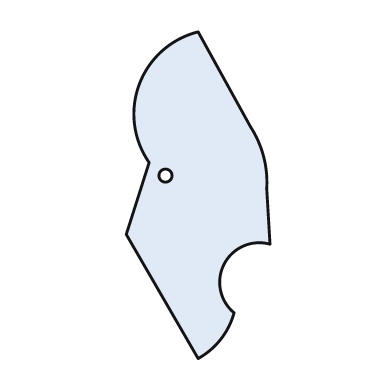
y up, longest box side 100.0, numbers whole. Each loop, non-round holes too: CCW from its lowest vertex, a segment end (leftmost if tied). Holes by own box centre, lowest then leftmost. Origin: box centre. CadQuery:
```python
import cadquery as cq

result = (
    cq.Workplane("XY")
    .moveTo(0.0, -50.0)
    .threePointArc((7.0, -44.0), (11.0, -36.0))
    .threePointArc((8.0, -21.0), (22.0, -15.0))
    .lineTo(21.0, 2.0)
    .threePointArc((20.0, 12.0), (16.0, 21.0))
    .lineTo(0.0, 50.0)
    .threePointArc((-18.0, 34.0), (-15.0, 10.0))
    .lineTo(-22.0, -12.0)
    .close()
    .moveTo(-10.0, 6.0)
    .circle(2.0)
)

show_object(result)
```